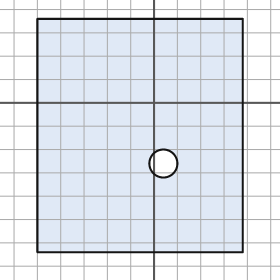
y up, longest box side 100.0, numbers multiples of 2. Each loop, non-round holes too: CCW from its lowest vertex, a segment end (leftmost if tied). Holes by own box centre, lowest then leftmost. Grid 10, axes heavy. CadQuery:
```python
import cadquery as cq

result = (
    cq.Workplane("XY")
    .moveTo(-50.0, -64.0)
    .lineTo(38.0, -64.0)
    .lineTo(38.0, 36.0)
    .lineTo(-50.0, 36.0)
    .close()
    .moveTo(4.0, -26.0)
    .circle(6.0)
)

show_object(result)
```